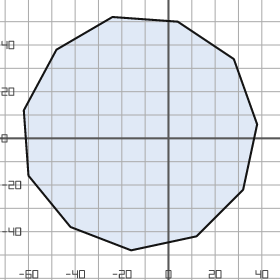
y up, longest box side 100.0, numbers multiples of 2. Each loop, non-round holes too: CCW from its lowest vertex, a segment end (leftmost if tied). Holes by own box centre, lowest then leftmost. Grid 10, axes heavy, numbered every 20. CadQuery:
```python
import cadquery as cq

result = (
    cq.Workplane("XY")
    .moveTo(-16.0, -48.0)
    .lineTo(12.0, -42.0)
    .lineTo(32.0, -22.0)
    .lineTo(38.0, 6.0)
    .lineTo(28.0, 34.0)
    .lineTo(4.0, 50.0)
    .lineTo(-24.0, 52.0)
    .lineTo(-48.0, 38.0)
    .lineTo(-62.0, 12.0)
    .lineTo(-60.0, -16.0)
    .lineTo(-42.0, -38.0)
    .close()
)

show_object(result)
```